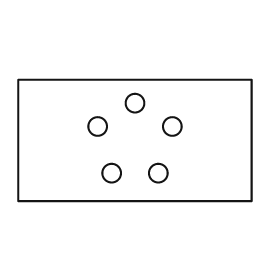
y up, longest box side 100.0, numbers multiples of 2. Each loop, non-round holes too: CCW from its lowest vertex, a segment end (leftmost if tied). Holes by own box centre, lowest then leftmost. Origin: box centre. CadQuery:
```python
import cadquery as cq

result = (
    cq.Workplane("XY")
    .moveTo(-50.0, -26.0)
    .lineTo(50.0, -26.0)
    .lineTo(50.0, 26.0)
    .lineTo(-50.0, 26.0)
    .close()
    .moveTo(-10.0, -14.0)
    .circle(4.0)
    .moveTo(10.0, -14.0)
    .circle(4.0)
    .moveTo(-16.0, 6.0)
    .circle(4.0)
    .moveTo(16.0, 6.0)
    .circle(4.0)
    .moveTo(0.0, 16.0)
    .circle(4.0)
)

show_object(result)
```